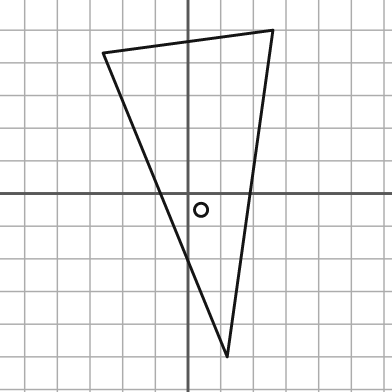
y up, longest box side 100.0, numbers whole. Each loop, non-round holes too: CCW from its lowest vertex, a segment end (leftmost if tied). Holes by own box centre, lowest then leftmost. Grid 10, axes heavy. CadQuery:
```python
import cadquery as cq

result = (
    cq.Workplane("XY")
    .moveTo(12.0, -50.0)
    .lineTo(26.0, 50.0)
    .lineTo(-26.0, 43.0)
    .close()
    .moveTo(4.0, -5.0)
    .circle(2.0)
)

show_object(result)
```